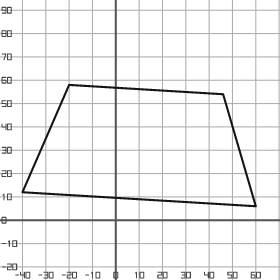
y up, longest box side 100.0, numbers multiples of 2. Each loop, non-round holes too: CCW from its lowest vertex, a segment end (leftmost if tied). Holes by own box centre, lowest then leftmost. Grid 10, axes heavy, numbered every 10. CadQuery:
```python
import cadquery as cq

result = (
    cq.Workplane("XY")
    .moveTo(60.0, 6.0)
    .lineTo(46.0, 54.0)
    .lineTo(-20.0, 58.0)
    .lineTo(-40.0, 12.0)
    .close()
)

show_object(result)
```